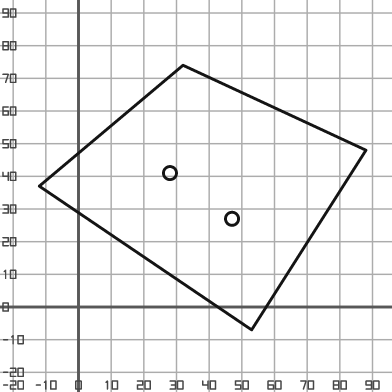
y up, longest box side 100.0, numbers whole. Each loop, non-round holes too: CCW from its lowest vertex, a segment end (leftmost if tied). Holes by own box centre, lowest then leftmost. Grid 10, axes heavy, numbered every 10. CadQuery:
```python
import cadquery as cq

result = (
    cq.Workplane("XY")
    .moveTo(53.0, -7.0)
    .lineTo(88.0, 48.0)
    .lineTo(32.0, 74.0)
    .lineTo(-12.0, 37.0)
    .close()
    .moveTo(47.0, 27.0)
    .circle(2.0)
    .moveTo(28.0, 41.0)
    .circle(2.0)
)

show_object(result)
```